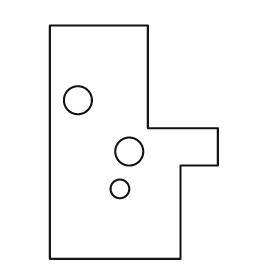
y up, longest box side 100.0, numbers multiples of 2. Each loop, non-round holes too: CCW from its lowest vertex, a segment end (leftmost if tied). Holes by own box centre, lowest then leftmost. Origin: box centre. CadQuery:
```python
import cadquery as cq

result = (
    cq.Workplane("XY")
    .moveTo(-36.0, -50.0)
    .lineTo(20.0, -50.0)
    .lineTo(20.0, -10.0)
    .lineTo(36.0, -10.0)
    .lineTo(36.0, 6.0)
    .lineTo(6.0, 6.0)
    .lineTo(6.0, 50.0)
    .lineTo(-36.0, 50.0)
    .close()
    .moveTo(-6.0, -20.0)
    .circle(4.0)
    .moveTo(-2.0, -4.0)
    .circle(6.0)
    .moveTo(-24.0, 18.0)
    .circle(6.0)
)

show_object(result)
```